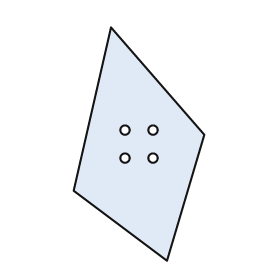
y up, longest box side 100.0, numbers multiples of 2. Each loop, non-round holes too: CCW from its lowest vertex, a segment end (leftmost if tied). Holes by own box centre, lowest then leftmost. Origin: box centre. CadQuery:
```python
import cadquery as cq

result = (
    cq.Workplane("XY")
    .moveTo(12.0, -50.0)
    .lineTo(28.0, 4.0)
    .lineTo(-12.0, 50.0)
    .lineTo(-28.0, -20.0)
    .close()
    .moveTo(-6.0, -6.0)
    .circle(2.0)
    .moveTo(6.0, -6.0)
    .circle(2.0)
    .moveTo(-6.0, 6.0)
    .circle(2.0)
    .moveTo(6.0, 6.0)
    .circle(2.0)
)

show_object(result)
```